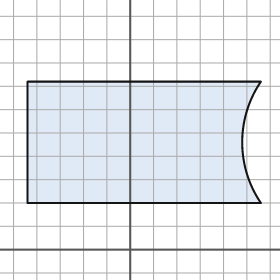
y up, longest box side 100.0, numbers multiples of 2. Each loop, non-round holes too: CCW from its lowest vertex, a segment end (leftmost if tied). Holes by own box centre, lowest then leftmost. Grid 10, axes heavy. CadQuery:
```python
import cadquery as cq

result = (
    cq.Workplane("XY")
    .moveTo(-44.0, 20.0)
    .lineTo(56.0, 20.0)
    .threePointArc((48.0, 46.0), (56.0, 72.0))
    .lineTo(-44.0, 72.0)
    .close()
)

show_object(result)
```